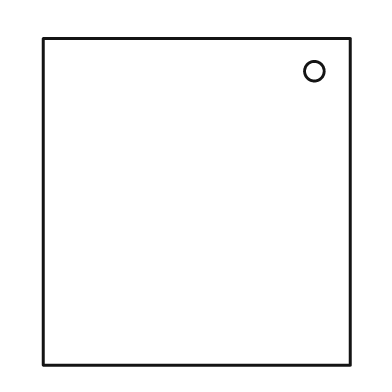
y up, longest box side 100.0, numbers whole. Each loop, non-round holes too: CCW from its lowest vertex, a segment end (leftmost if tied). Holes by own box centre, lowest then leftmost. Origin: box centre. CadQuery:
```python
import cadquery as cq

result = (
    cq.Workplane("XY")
    .moveTo(-47.0, -50.0)
    .lineTo(47.0, -50.0)
    .lineTo(47.0, 50.0)
    .lineTo(-47.0, 50.0)
    .close()
    .moveTo(36.0, 40.0)
    .circle(3.0)
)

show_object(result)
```